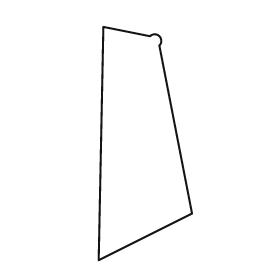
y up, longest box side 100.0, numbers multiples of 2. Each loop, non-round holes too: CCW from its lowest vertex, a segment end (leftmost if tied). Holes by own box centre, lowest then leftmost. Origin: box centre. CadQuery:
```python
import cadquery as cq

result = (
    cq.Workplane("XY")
    .moveTo(-20.0, -50.0)
    .lineTo(20.0, -30.0)
    .lineTo(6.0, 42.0)
    .threePointArc((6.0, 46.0), (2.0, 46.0))
    .lineTo(-18.0, 50.0)
    .close()
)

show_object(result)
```